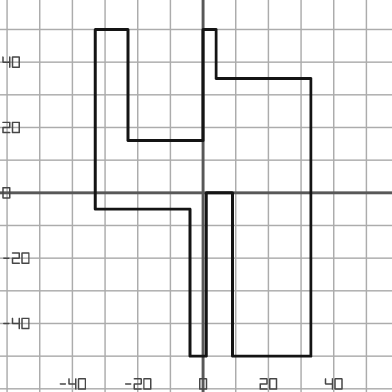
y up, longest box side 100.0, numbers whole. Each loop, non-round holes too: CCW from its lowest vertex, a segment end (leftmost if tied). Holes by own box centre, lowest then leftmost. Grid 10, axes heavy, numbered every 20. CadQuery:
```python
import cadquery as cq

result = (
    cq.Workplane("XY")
    .moveTo(-4.0, -50.0)
    .lineTo(1.0, -50.0)
    .lineTo(1.0, 0.0)
    .lineTo(9.0, 0.0)
    .lineTo(9.0, -50.0)
    .lineTo(33.0, -50.0)
    .lineTo(33.0, 35.0)
    .lineTo(4.0, 35.0)
    .lineTo(4.0, 50.0)
    .lineTo(0.0, 50.0)
    .lineTo(0.0, 16.0)
    .lineTo(-23.0, 16.0)
    .lineTo(-23.0, 50.0)
    .lineTo(-33.0, 50.0)
    .lineTo(-33.0, -5.0)
    .lineTo(-4.0, -5.0)
    .close()
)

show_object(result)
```